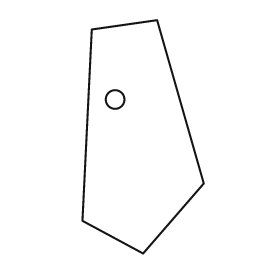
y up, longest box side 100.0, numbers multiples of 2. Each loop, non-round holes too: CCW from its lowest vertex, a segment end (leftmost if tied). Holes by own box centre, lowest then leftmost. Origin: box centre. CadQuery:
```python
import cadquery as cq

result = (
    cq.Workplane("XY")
    .moveTo(0.0, -50.0)
    .lineTo(26.0, -20.0)
    .lineTo(6.0, 50.0)
    .lineTo(-22.0, 46.0)
    .lineTo(-26.0, -36.0)
    .close()
    .moveTo(-12.0, 16.0)
    .circle(4.0)
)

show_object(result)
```